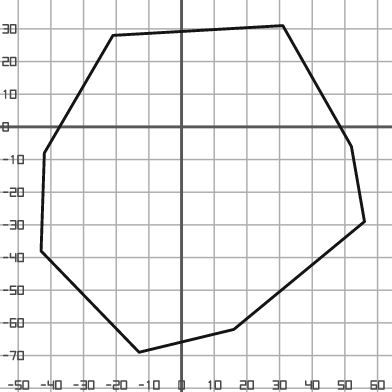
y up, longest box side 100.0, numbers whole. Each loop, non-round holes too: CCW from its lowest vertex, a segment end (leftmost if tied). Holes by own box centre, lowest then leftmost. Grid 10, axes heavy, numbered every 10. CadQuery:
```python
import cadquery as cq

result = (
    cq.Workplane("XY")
    .moveTo(-13.0, -69.0)
    .lineTo(16.0, -62.0)
    .lineTo(56.0, -29.0)
    .lineTo(52.0, -6.0)
    .lineTo(31.0, 31.0)
    .lineTo(-21.0, 28.0)
    .lineTo(-42.0, -8.0)
    .lineTo(-43.0, -38.0)
    .close()
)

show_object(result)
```